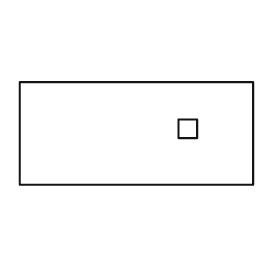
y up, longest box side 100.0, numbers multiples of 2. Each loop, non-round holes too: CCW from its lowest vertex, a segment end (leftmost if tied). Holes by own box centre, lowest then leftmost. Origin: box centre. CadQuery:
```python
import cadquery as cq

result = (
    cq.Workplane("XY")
    .moveTo(-50.0, -22.0)
    .lineTo(50.0, -22.0)
    .lineTo(50.0, 22.0)
    .lineTo(-50.0, 22.0)
    .close()
    .moveTo(18.0, -2.0)
    .lineTo(26.0, -2.0)
    .lineTo(26.0, 6.0)
    .lineTo(18.0, 6.0)
    .close()
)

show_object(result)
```